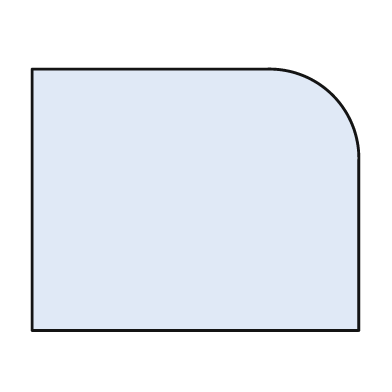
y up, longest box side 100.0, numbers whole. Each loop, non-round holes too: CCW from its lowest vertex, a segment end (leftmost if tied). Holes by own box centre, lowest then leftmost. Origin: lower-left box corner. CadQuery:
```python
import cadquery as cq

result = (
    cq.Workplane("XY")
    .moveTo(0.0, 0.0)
    .lineTo(100.0, 0.0)
    .lineTo(100.0, 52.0)
    .threePointArc((92.0, 72.0), (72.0, 80.0))
    .lineTo(0.0, 80.0)
    .close()
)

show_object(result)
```